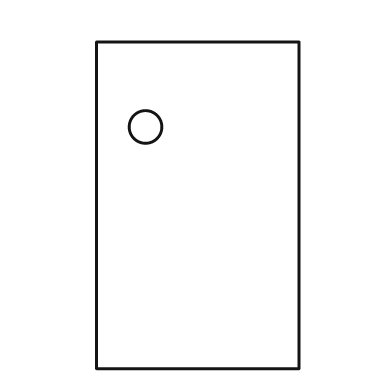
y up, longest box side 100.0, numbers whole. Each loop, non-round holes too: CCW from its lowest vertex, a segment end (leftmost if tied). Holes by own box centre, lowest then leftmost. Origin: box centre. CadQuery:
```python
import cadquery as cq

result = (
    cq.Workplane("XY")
    .moveTo(-31.0, -50.0)
    .lineTo(31.0, -50.0)
    .lineTo(31.0, 50.0)
    .lineTo(-31.0, 50.0)
    .close()
    .moveTo(-16.0, 24.0)
    .circle(5.0)
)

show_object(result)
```